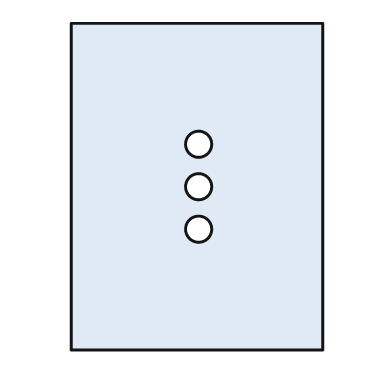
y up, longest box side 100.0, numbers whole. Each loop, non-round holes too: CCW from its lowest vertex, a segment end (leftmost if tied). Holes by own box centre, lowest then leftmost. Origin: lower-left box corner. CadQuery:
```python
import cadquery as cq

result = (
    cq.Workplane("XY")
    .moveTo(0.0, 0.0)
    .lineTo(77.0, 0.0)
    .lineTo(77.0, 100.0)
    .lineTo(0.0, 100.0)
    .close()
    .moveTo(39.0, 37.0)
    .circle(4.0)
    .moveTo(39.0, 50.0)
    .circle(4.0)
    .moveTo(39.0, 63.0)
    .circle(4.0)
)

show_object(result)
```